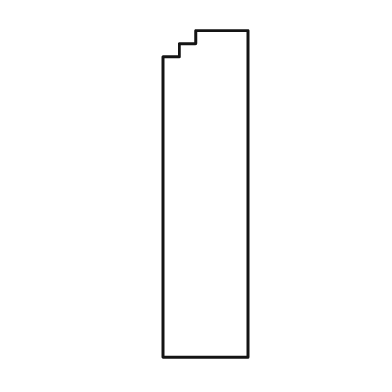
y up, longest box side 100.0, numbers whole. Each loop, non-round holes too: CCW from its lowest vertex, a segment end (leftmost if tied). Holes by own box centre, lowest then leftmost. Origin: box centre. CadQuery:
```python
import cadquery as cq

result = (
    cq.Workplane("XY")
    .moveTo(-13.0, -50.0)
    .lineTo(13.0, -50.0)
    .lineTo(13.0, 50.0)
    .lineTo(-3.0, 50.0)
    .lineTo(-3.0, 46.0)
    .lineTo(-8.0, 46.0)
    .lineTo(-8.0, 42.0)
    .lineTo(-13.0, 42.0)
    .close()
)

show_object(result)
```